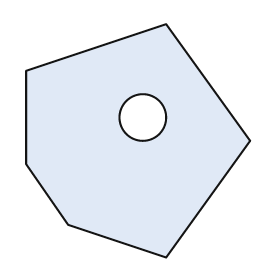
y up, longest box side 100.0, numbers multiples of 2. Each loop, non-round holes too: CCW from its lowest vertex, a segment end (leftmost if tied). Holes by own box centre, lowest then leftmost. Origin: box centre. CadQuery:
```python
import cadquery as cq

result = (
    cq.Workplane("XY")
    .moveTo(12.0, -50.0)
    .lineTo(48.0, 0.0)
    .lineTo(12.0, 50.0)
    .lineTo(-48.0, 30.0)
    .lineTo(-48.0, -10.0)
    .lineTo(-30.0, -36.0)
    .close()
    .moveTo(2.0, 10.0)
    .circle(10.0)
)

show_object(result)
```